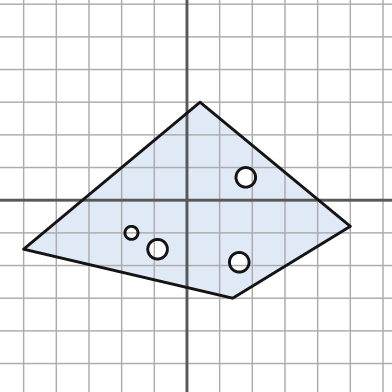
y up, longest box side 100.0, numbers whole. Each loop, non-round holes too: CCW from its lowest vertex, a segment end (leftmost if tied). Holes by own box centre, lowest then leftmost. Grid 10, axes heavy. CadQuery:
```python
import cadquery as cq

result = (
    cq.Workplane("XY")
    .moveTo(14.0, -30.0)
    .lineTo(50.0, -8.0)
    .lineTo(4.0, 30.0)
    .lineTo(-50.0, -15.0)
    .close()
    .moveTo(16.0, -19.0)
    .circle(3.0)
    .moveTo(-9.0, -15.0)
    .circle(3.0)
    .moveTo(-17.0, -10.0)
    .circle(2.0)
    .moveTo(18.0, 7.0)
    .circle(3.0)
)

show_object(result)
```